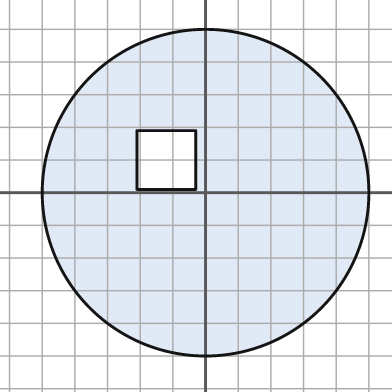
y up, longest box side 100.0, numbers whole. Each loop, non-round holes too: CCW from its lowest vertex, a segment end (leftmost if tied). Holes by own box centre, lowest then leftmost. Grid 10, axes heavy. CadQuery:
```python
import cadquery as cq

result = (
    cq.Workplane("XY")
    .moveTo(0.0, 0.0)
    .circle(50.0)
    .moveTo(-21.0, 1.0)
    .lineTo(-3.0, 1.0)
    .lineTo(-3.0, 19.0)
    .lineTo(-21.0, 19.0)
    .close()
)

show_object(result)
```